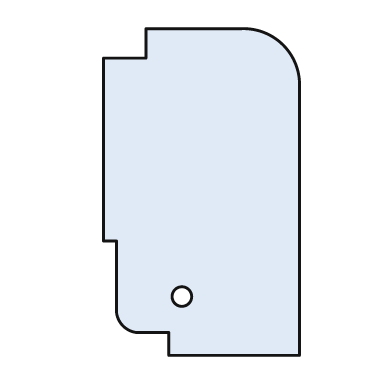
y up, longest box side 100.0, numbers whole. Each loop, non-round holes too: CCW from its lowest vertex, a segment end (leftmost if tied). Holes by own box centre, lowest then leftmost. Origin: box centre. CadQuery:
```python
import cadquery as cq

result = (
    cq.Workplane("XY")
    .moveTo(-10.0, -50.0)
    .lineTo(30.0, -50.0)
    .lineTo(30.0, 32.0)
    .threePointArc((25.0, 45.0), (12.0, 50.0))
    .lineTo(-17.0, 50.0)
    .lineTo(-17.0, 41.0)
    .lineTo(-30.0, 41.0)
    .lineTo(-30.0, -15.0)
    .lineTo(-26.0, -15.0)
    .lineTo(-26.0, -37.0)
    .threePointArc((-24.0, -41.0), (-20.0, -43.0))
    .lineTo(-10.0, -43.0)
    .close()
    .moveTo(-6.0, -32.0)
    .circle(3.0)
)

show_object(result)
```